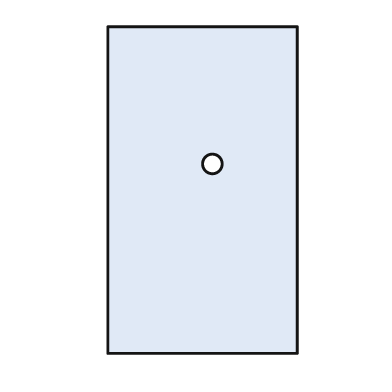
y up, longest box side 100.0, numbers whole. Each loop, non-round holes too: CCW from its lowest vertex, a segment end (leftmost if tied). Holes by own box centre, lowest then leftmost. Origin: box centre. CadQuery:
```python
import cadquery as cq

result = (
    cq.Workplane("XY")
    .moveTo(-29.0, -50.0)
    .lineTo(29.0, -50.0)
    .lineTo(29.0, 50.0)
    .lineTo(-29.0, 50.0)
    .close()
    .moveTo(3.0, 8.0)
    .circle(3.0)
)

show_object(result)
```